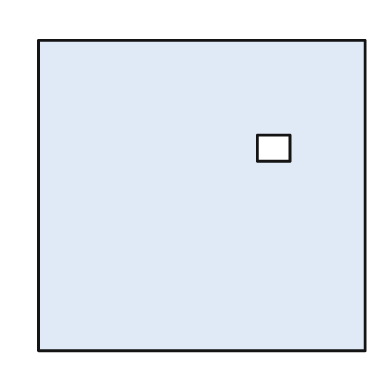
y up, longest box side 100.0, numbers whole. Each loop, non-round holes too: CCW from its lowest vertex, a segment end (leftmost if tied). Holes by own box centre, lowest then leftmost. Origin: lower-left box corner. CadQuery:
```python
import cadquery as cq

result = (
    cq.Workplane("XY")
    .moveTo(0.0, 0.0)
    .lineTo(100.0, 0.0)
    .lineTo(100.0, 95.0)
    .lineTo(0.0, 95.0)
    .close()
    .moveTo(67.0, 58.0)
    .lineTo(77.0, 58.0)
    .lineTo(77.0, 66.0)
    .lineTo(67.0, 66.0)
    .close()
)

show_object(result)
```